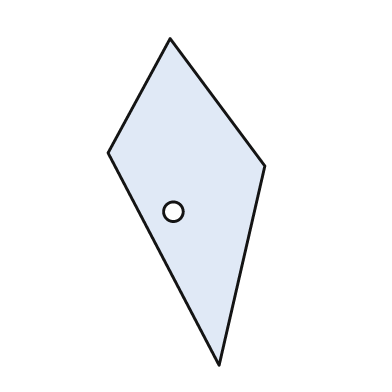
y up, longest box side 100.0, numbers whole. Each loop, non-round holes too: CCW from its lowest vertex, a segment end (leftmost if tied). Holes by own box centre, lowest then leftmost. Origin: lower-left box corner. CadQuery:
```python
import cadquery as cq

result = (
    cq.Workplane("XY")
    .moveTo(34.0, 0.0)
    .lineTo(48.0, 61.0)
    .lineTo(19.0, 100.0)
    .lineTo(0.0, 65.0)
    .close()
    .moveTo(20.0, 47.0)
    .circle(3.0)
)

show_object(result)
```